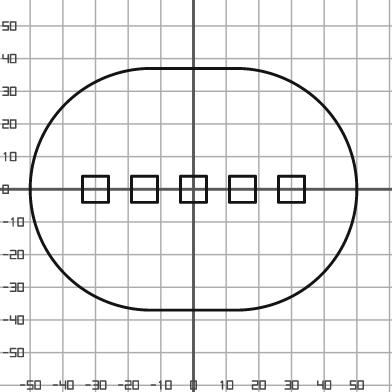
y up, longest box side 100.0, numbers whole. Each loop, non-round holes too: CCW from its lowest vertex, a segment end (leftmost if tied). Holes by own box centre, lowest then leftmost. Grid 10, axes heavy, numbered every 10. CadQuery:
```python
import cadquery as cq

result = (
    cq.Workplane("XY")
    .moveTo(-13.0, -37.0)
    .lineTo(13.0, -37.0)
    .threePointArc((50.0, 0.0), (13.0, 37.0))
    .lineTo(-13.0, 37.0)
    .threePointArc((-50.0, 0.0), (-13.0, -37.0))
    .close()
    .moveTo(-34.0, -4.0)
    .lineTo(-26.0, -4.0)
    .lineTo(-26.0, 4.0)
    .lineTo(-34.0, 4.0)
    .close()
    .moveTo(-19.0, -4.0)
    .lineTo(-11.0, -4.0)
    .lineTo(-11.0, 4.0)
    .lineTo(-19.0, 4.0)
    .close()
    .moveTo(-4.0, -4.0)
    .lineTo(4.0, -4.0)
    .lineTo(4.0, 4.0)
    .lineTo(-4.0, 4.0)
    .close()
    .moveTo(11.0, -4.0)
    .lineTo(19.0, -4.0)
    .lineTo(19.0, 4.0)
    .lineTo(11.0, 4.0)
    .close()
    .moveTo(26.0, -4.0)
    .lineTo(34.0, -4.0)
    .lineTo(34.0, 4.0)
    .lineTo(26.0, 4.0)
    .close()
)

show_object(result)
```